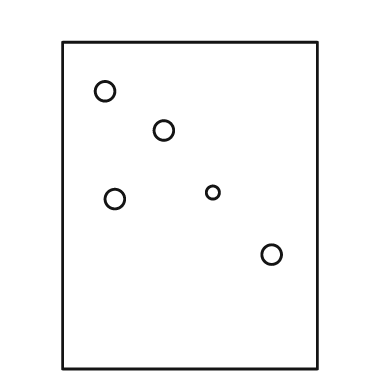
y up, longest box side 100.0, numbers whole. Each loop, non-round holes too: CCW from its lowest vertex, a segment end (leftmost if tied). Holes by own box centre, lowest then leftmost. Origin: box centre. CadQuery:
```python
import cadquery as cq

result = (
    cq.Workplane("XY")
    .moveTo(-39.0, -50.0)
    .lineTo(39.0, -50.0)
    .lineTo(39.0, 50.0)
    .lineTo(-39.0, 50.0)
    .close()
    .moveTo(25.0, -15.0)
    .circle(3.0)
    .moveTo(-23.0, 2.0)
    .circle(3.0)
    .moveTo(7.0, 4.0)
    .circle(2.0)
    .moveTo(-8.0, 23.0)
    .circle(3.0)
    .moveTo(-26.0, 35.0)
    .circle(3.0)
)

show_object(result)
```